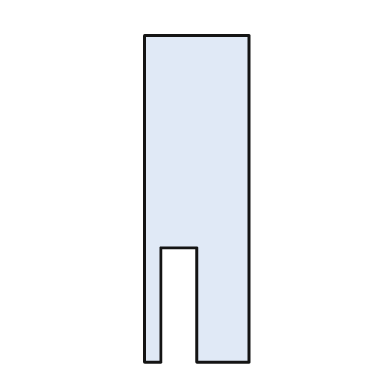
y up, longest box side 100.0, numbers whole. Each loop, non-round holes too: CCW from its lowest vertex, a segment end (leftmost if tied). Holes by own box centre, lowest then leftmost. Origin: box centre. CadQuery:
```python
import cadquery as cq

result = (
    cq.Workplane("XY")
    .moveTo(-16.0, -50.0)
    .lineTo(-11.0, -50.0)
    .lineTo(-11.0, -15.0)
    .lineTo(0.0, -15.0)
    .lineTo(0.0, -50.0)
    .lineTo(16.0, -50.0)
    .lineTo(16.0, 50.0)
    .lineTo(-16.0, 50.0)
    .close()
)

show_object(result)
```